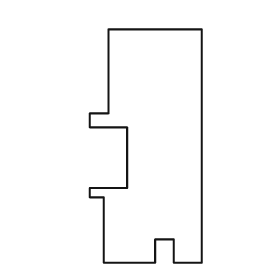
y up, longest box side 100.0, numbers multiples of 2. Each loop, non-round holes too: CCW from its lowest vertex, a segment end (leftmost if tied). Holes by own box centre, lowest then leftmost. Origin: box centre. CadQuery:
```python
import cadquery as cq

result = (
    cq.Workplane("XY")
    .moveTo(-18.0, -50.0)
    .lineTo(4.0, -50.0)
    .lineTo(4.0, -40.0)
    .lineTo(12.0, -40.0)
    .lineTo(12.0, -50.0)
    .lineTo(24.0, -50.0)
    .lineTo(24.0, 50.0)
    .lineTo(-16.0, 50.0)
    .lineTo(-16.0, 14.0)
    .lineTo(-24.0, 14.0)
    .lineTo(-24.0, 8.0)
    .lineTo(-8.0, 8.0)
    .lineTo(-8.0, -18.0)
    .lineTo(-24.0, -18.0)
    .lineTo(-24.0, -22.0)
    .lineTo(-18.0, -22.0)
    .close()
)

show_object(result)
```